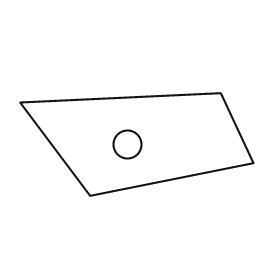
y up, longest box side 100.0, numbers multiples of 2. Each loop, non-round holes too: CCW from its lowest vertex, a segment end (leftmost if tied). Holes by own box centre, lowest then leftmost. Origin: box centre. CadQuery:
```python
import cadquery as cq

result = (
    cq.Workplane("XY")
    .moveTo(-20.0, -22.0)
    .lineTo(50.0, -8.0)
    .lineTo(36.0, 22.0)
    .lineTo(-50.0, 18.0)
    .close()
    .moveTo(-4.0, 0.0)
    .circle(6.0)
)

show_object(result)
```